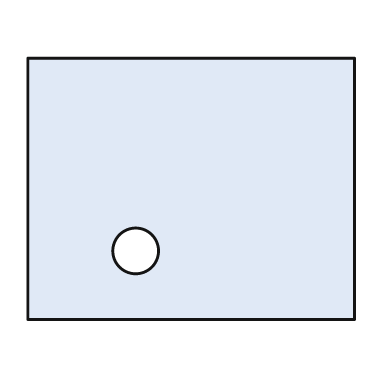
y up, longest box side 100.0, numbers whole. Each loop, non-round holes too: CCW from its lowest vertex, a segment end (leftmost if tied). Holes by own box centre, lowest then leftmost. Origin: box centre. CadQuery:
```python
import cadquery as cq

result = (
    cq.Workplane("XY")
    .moveTo(-50.0, -40.0)
    .lineTo(50.0, -40.0)
    .lineTo(50.0, 40.0)
    .lineTo(-50.0, 40.0)
    .close()
    .moveTo(-17.0, -19.0)
    .circle(7.0)
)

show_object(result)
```